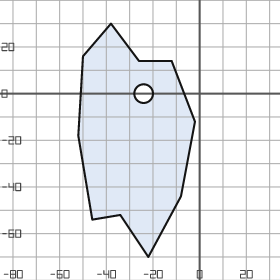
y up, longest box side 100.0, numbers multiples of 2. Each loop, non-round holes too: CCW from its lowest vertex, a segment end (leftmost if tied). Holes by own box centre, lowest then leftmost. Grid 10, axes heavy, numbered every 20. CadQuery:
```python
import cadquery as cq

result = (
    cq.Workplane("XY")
    .moveTo(-22.0, -70.0)
    .lineTo(-8.0, -44.0)
    .lineTo(-2.0, -12.0)
    .lineTo(-12.0, 14.0)
    .lineTo(-26.0, 14.0)
    .lineTo(-38.0, 30.0)
    .lineTo(-50.0, 16.0)
    .lineTo(-52.0, -18.0)
    .lineTo(-46.0, -54.0)
    .lineTo(-34.0, -52.0)
    .close()
    .moveTo(-24.0, 0.0)
    .circle(4.0)
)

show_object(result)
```